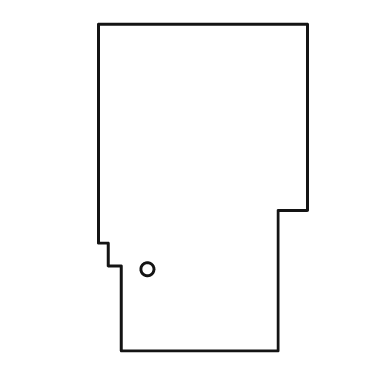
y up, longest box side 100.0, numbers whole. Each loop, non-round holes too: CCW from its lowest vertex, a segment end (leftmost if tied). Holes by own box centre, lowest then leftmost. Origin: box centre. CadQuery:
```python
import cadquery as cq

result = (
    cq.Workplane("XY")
    .moveTo(-25.0, -50.0)
    .lineTo(23.0, -50.0)
    .lineTo(23.0, -7.0)
    .lineTo(32.0, -7.0)
    .lineTo(32.0, 50.0)
    .lineTo(-32.0, 50.0)
    .lineTo(-32.0, -17.0)
    .lineTo(-29.0, -17.0)
    .lineTo(-29.0, -24.0)
    .lineTo(-25.0, -24.0)
    .close()
    .moveTo(-17.0, -25.0)
    .circle(2.0)
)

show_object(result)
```